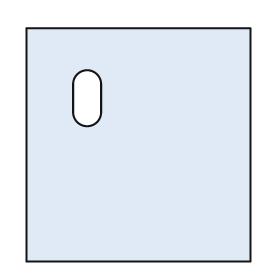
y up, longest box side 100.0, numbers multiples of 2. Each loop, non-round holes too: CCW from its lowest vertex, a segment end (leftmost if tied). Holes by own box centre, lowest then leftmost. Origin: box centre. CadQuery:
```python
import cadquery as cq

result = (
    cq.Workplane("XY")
    .moveTo(-48.0, -50.0)
    .lineTo(48.0, -50.0)
    .lineTo(48.0, 50.0)
    .lineTo(-48.0, 50.0)
    .close()
    .moveTo(-28.0, 14.0)
    .threePointArc((-22.0, 8.0), (-16.0, 14.0))
    .lineTo(-16.0, 26.0)
    .threePointArc((-22.0, 32.0), (-28.0, 26.0))
    .close()
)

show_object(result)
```